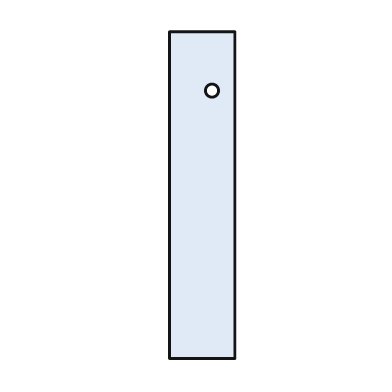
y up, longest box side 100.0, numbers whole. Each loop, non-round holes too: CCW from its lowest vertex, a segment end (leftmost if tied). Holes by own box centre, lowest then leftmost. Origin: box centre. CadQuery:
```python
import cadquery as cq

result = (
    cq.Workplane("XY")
    .moveTo(-10.0, -50.0)
    .lineTo(10.0, -50.0)
    .lineTo(10.0, 50.0)
    .lineTo(-10.0, 50.0)
    .close()
    .moveTo(3.0, 32.0)
    .circle(2.0)
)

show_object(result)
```